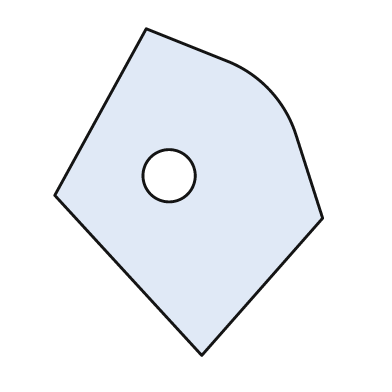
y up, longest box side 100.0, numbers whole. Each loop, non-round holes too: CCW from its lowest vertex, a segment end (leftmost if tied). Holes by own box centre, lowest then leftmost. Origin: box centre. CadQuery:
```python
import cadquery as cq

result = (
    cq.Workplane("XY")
    .moveTo(4.0, -50.0)
    .lineTo(41.0, -8.0)
    .lineTo(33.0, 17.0)
    .threePointArc((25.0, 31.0), (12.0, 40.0))
    .lineTo(-13.0, 50.0)
    .lineTo(-41.0, -1.0)
    .close()
    .moveTo(-6.0, 5.0)
    .circle(8.0)
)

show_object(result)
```